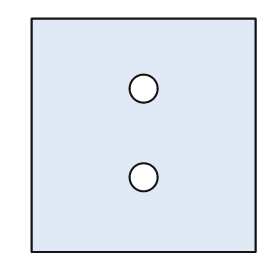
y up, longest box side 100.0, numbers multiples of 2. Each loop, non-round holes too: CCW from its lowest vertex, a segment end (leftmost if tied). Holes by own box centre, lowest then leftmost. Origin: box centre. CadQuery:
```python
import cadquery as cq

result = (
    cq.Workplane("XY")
    .moveTo(-48.0, -50.0)
    .lineTo(48.0, -50.0)
    .lineTo(48.0, 50.0)
    .lineTo(-48.0, 50.0)
    .close()
    .moveTo(0.0, -18.0)
    .circle(6.0)
    .moveTo(0.0, 20.0)
    .circle(6.0)
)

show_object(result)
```